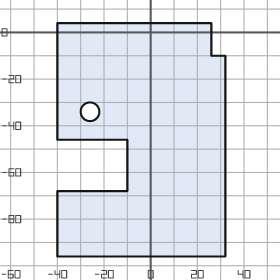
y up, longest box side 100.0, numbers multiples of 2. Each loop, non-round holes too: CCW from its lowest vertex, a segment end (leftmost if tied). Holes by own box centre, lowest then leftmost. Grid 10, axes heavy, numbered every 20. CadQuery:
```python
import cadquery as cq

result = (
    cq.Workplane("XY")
    .moveTo(-40.0, -96.0)
    .lineTo(32.0, -96.0)
    .lineTo(32.0, -10.0)
    .lineTo(26.0, -10.0)
    .lineTo(26.0, 4.0)
    .lineTo(-40.0, 4.0)
    .lineTo(-40.0, -46.0)
    .lineTo(-10.0, -46.0)
    .lineTo(-10.0, -68.0)
    .lineTo(-40.0, -68.0)
    .close()
    .moveTo(-26.0, -34.0)
    .circle(4.0)
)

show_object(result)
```